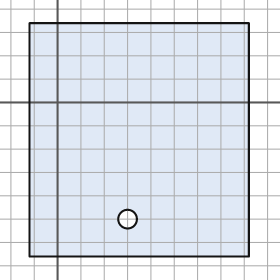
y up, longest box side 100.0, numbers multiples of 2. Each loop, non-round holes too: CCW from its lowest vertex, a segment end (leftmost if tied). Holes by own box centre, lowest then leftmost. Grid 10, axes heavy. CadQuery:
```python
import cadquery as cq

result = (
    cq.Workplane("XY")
    .moveTo(-12.0, -66.0)
    .lineTo(82.0, -66.0)
    .lineTo(82.0, 34.0)
    .lineTo(-12.0, 34.0)
    .close()
    .moveTo(30.0, -50.0)
    .circle(4.0)
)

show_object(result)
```